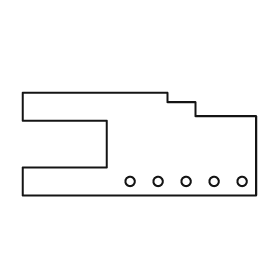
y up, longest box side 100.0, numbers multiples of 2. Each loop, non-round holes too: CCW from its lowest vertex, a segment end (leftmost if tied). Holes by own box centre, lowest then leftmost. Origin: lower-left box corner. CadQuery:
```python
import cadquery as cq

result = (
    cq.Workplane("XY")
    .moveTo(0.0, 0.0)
    .lineTo(100.0, 0.0)
    .lineTo(100.0, 34.0)
    .lineTo(74.0, 34.0)
    .lineTo(74.0, 40.0)
    .lineTo(62.0, 40.0)
    .lineTo(62.0, 44.0)
    .lineTo(0.0, 44.0)
    .lineTo(0.0, 32.0)
    .lineTo(36.0, 32.0)
    .lineTo(36.0, 12.0)
    .lineTo(0.0, 12.0)
    .close()
    .moveTo(46.0, 6.0)
    .circle(2.0)
    .moveTo(58.0, 6.0)
    .circle(2.0)
    .moveTo(70.0, 6.0)
    .circle(2.0)
    .moveTo(82.0, 6.0)
    .circle(2.0)
    .moveTo(94.0, 6.0)
    .circle(2.0)
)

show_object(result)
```